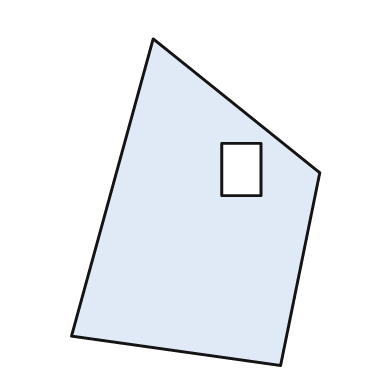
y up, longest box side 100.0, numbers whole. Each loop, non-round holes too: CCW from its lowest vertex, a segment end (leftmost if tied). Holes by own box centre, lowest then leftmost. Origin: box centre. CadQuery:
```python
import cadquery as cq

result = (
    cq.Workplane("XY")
    .moveTo(26.0, -50.0)
    .lineTo(38.0, 9.0)
    .lineTo(-13.0, 50.0)
    .lineTo(-38.0, -41.0)
    .close()
    .moveTo(8.0, 2.0)
    .lineTo(20.0, 2.0)
    .lineTo(20.0, 18.0)
    .lineTo(8.0, 18.0)
    .close()
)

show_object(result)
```